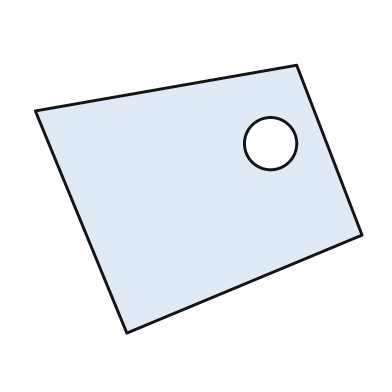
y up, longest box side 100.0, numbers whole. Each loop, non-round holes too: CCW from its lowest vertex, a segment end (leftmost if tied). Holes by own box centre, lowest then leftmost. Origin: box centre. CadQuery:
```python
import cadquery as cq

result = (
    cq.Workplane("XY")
    .moveTo(-22.0, -41.0)
    .lineTo(50.0, -11.0)
    .lineTo(30.0, 41.0)
    .lineTo(-50.0, 27.0)
    .close()
    .moveTo(22.0, 17.0)
    .circle(8.0)
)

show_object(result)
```